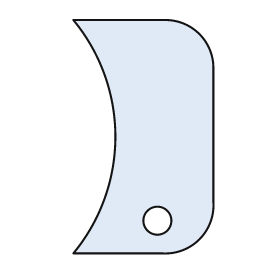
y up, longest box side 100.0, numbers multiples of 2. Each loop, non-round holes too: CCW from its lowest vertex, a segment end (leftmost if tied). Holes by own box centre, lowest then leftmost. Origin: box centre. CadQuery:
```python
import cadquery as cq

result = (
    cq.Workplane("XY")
    .moveTo(-30.0, -50.0)
    .lineTo(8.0, -50.0)
    .threePointArc((24.0, -44.0), (30.0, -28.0))
    .lineTo(30.0, 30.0)
    .threePointArc((24.0, 44.0), (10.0, 50.0))
    .lineTo(-30.0, 50.0)
    .threePointArc((-12.0, 0.0), (-30.0, -50.0))
    .close()
    .moveTo(6.0, -36.0)
    .circle(6.0)
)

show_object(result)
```